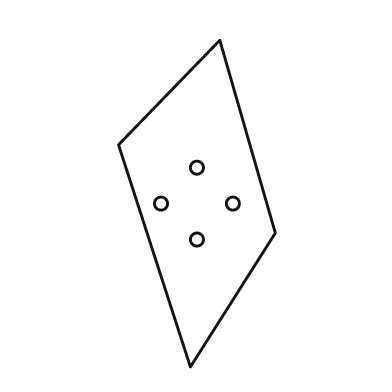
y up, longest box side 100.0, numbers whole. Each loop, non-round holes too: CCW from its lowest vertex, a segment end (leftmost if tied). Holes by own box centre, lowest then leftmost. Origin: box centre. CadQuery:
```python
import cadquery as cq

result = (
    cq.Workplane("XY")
    .moveTo(-2.0, -50.0)
    .lineTo(24.0, -9.0)
    .lineTo(7.0, 50.0)
    .lineTo(-24.0, 18.0)
    .close()
    .moveTo(0.0, -11.0)
    .circle(2.0)
    .moveTo(-11.0, 0.0)
    .circle(2.0)
    .moveTo(11.0, 0.0)
    .circle(2.0)
    .moveTo(0.0, 11.0)
    .circle(2.0)
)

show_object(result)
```